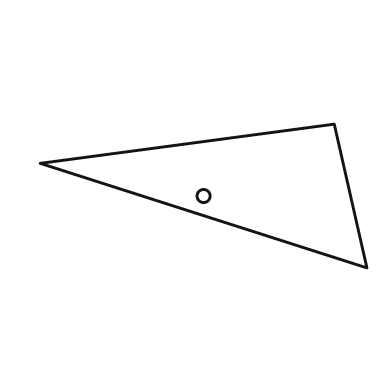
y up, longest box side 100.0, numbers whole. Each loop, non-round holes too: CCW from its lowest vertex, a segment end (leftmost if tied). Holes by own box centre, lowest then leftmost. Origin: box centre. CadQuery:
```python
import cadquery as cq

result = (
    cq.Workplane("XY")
    .moveTo(50.0, -22.0)
    .lineTo(40.0, 22.0)
    .lineTo(-50.0, 10.0)
    .close()
    .moveTo(0.0, 0.0)
    .circle(2.0)
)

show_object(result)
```